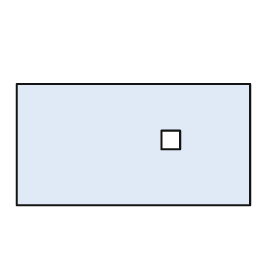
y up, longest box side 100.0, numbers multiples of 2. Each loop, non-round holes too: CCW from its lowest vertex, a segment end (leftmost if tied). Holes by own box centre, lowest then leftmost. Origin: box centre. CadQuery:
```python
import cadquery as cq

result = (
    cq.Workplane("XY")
    .moveTo(-50.0, -26.0)
    .lineTo(50.0, -26.0)
    .lineTo(50.0, 26.0)
    .lineTo(-50.0, 26.0)
    .close()
    .moveTo(12.0, -2.0)
    .lineTo(20.0, -2.0)
    .lineTo(20.0, 6.0)
    .lineTo(12.0, 6.0)
    .close()
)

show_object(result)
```